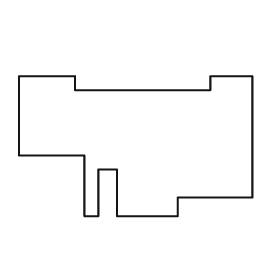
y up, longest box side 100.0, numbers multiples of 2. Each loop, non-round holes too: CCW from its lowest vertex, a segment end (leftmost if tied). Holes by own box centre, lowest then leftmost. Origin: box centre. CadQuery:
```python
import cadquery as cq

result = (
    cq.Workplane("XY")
    .moveTo(-22.0, -30.0)
    .lineTo(-16.0, -30.0)
    .lineTo(-16.0, -10.0)
    .lineTo(-8.0, -10.0)
    .lineTo(-8.0, -30.0)
    .lineTo(18.0, -30.0)
    .lineTo(18.0, -22.0)
    .lineTo(50.0, -22.0)
    .lineTo(50.0, 30.0)
    .lineTo(32.0, 30.0)
    .lineTo(32.0, 24.0)
    .lineTo(-26.0, 24.0)
    .lineTo(-26.0, 30.0)
    .lineTo(-50.0, 30.0)
    .lineTo(-50.0, -4.0)
    .lineTo(-22.0, -4.0)
    .close()
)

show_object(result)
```